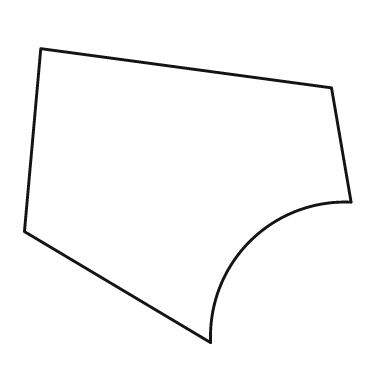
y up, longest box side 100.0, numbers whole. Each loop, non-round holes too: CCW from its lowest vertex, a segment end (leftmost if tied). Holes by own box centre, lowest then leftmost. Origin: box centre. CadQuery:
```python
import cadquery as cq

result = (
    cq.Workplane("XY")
    .moveTo(7.0, -45.0)
    .threePointArc((19.0, -14.0), (50.0, -2.0))
    .lineTo(44.0, 33.0)
    .lineTo(-45.0, 45.0)
    .lineTo(-50.0, -11.0)
    .close()
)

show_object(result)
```